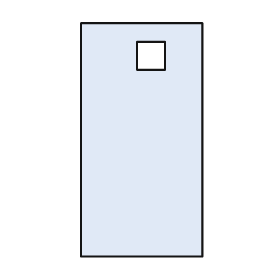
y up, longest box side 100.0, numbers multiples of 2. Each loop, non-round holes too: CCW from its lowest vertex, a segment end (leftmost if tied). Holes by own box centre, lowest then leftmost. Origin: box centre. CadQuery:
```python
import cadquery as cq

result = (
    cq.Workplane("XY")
    .moveTo(-26.0, -50.0)
    .lineTo(26.0, -50.0)
    .lineTo(26.0, 50.0)
    .lineTo(-26.0, 50.0)
    .close()
    .moveTo(-2.0, 30.0)
    .lineTo(10.0, 30.0)
    .lineTo(10.0, 42.0)
    .lineTo(-2.0, 42.0)
    .close()
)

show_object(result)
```